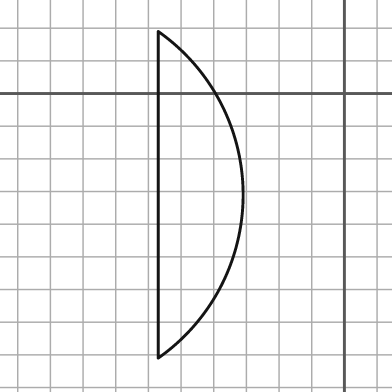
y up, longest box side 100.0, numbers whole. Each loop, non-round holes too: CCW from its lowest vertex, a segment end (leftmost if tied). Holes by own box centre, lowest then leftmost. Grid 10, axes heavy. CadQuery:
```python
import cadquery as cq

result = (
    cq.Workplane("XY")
    .moveTo(-57.0, -81.0)
    .threePointArc((-31.0, -31.0), (-57.0, 19.0))
    .close()
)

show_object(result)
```